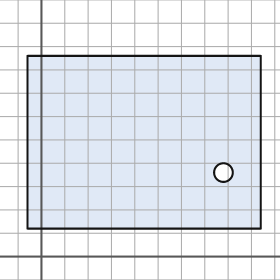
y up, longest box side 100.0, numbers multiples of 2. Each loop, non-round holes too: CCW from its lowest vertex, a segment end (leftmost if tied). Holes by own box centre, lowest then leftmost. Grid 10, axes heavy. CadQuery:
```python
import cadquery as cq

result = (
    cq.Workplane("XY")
    .moveTo(-6.0, 12.0)
    .lineTo(94.0, 12.0)
    .lineTo(94.0, 86.0)
    .lineTo(-6.0, 86.0)
    .close()
    .moveTo(78.0, 36.0)
    .circle(4.0)
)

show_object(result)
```